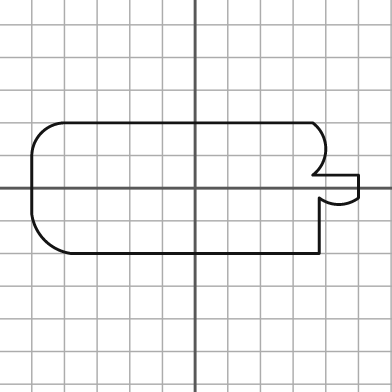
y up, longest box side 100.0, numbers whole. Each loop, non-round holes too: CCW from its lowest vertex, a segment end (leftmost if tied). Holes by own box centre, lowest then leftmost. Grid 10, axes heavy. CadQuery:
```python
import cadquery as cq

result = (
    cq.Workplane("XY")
    .moveTo(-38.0, -20.0)
    .lineTo(38.0, -20.0)
    .lineTo(38.0, -3.0)
    .threePointArc((44.0, -5.0), (50.0, -3.0))
    .lineTo(50.0, 4.0)
    .lineTo(36.0, 4.0)
    .threePointArc((40.0, 12.0), (36.0, 20.0))
    .lineTo(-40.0, 20.0)
    .threePointArc((-47.0, 17.0), (-50.0, 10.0))
    .lineTo(-50.0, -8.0)
    .threePointArc((-46.0, -16.0), (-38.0, -20.0))
    .close()
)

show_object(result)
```